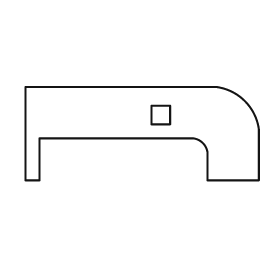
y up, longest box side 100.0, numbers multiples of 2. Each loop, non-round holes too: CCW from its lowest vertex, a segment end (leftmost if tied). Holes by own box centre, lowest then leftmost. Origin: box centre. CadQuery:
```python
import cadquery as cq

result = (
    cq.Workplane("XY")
    .moveTo(-50.0, -20.0)
    .lineTo(-44.0, -20.0)
    .lineTo(-44.0, -2.0)
    .lineTo(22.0, -2.0)
    .threePointArc((26.0, -4.0), (28.0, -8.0))
    .lineTo(28.0, -20.0)
    .lineTo(50.0, -20.0)
    .lineTo(50.0, 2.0)
    .threePointArc((44.0, 14.0), (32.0, 20.0))
    .lineTo(-50.0, 20.0)
    .close()
    .moveTo(4.0, 4.0)
    .lineTo(12.0, 4.0)
    .lineTo(12.0, 12.0)
    .lineTo(4.0, 12.0)
    .close()
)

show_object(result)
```